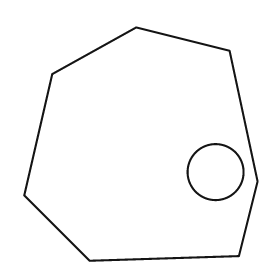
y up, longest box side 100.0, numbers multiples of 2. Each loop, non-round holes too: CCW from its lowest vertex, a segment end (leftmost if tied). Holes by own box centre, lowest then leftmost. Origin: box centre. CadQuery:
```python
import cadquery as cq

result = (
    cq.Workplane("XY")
    .moveTo(-22.0, -50.0)
    .lineTo(42.0, -48.0)
    .lineTo(50.0, -16.0)
    .lineTo(38.0, 40.0)
    .lineTo(-2.0, 50.0)
    .lineTo(-38.0, 30.0)
    .lineTo(-50.0, -22.0)
    .close()
    .moveTo(32.0, -12.0)
    .circle(12.0)
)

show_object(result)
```